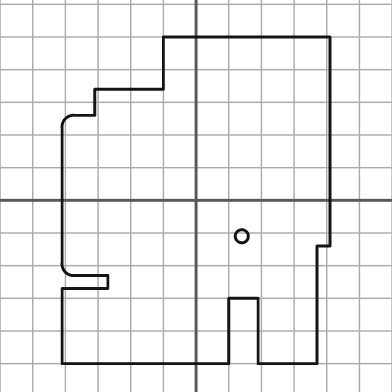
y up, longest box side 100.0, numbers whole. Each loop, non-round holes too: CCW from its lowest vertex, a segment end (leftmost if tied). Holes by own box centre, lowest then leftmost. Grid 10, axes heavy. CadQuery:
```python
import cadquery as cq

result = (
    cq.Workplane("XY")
    .moveTo(-41.0, -50.0)
    .lineTo(10.0, -50.0)
    .lineTo(10.0, -30.0)
    .lineTo(19.0, -30.0)
    .lineTo(19.0, -50.0)
    .lineTo(37.0, -50.0)
    .lineTo(37.0, -14.0)
    .lineTo(41.0, -14.0)
    .lineTo(41.0, 50.0)
    .lineTo(-10.0, 50.0)
    .lineTo(-10.0, 34.0)
    .lineTo(-31.0, 34.0)
    .lineTo(-31.0, 26.0)
    .lineTo(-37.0, 26.0)
    .threePointArc((-40.0, 25.0), (-41.0, 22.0))
    .lineTo(-41.0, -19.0)
    .threePointArc((-40.0, -22.0), (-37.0, -23.0))
    .lineTo(-27.0, -23.0)
    .lineTo(-27.0, -27.0)
    .lineTo(-41.0, -27.0)
    .close()
    .moveTo(14.0, -11.0)
    .circle(2.0)
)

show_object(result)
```